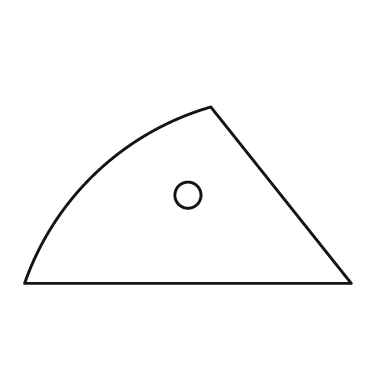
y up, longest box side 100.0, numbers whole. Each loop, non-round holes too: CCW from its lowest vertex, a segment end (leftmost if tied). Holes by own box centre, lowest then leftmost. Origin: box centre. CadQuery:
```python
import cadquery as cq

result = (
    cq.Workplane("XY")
    .moveTo(-50.0, -27.0)
    .lineTo(50.0, -27.0)
    .lineTo(7.0, 27.0)
    .threePointArc((-28.0, 7.0), (-50.0, -27.0))
    .close()
    .moveTo(0.0, 0.0)
    .circle(4.0)
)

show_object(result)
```